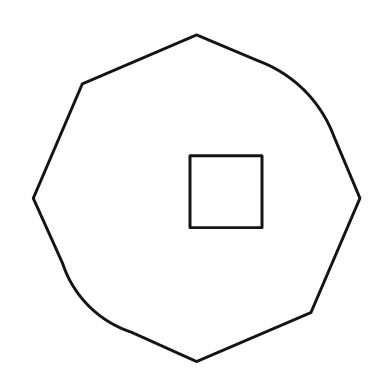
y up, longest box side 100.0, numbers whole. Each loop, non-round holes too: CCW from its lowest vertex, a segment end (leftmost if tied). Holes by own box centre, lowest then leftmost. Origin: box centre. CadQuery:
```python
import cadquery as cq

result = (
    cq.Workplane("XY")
    .moveTo(0.0, -50.0)
    .lineTo(35.0, -35.0)
    .lineTo(50.0, 0.0)
    .lineTo(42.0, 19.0)
    .threePointArc((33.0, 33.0), (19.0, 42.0))
    .lineTo(0.0, 50.0)
    .lineTo(-35.0, 35.0)
    .lineTo(-50.0, 0.0)
    .lineTo(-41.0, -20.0)
    .threePointArc((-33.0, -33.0), (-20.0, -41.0))
    .close()
    .moveTo(-2.0, -9.0)
    .lineTo(20.0, -9.0)
    .lineTo(20.0, 13.0)
    .lineTo(-2.0, 13.0)
    .close()
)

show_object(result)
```